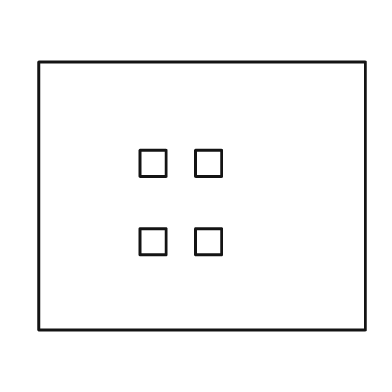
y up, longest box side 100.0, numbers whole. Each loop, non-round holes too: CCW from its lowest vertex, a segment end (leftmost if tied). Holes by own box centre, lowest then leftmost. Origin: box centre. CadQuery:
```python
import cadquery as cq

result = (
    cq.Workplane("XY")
    .moveTo(-50.0, -41.0)
    .lineTo(50.0, -41.0)
    .lineTo(50.0, 41.0)
    .lineTo(-50.0, 41.0)
    .close()
    .moveTo(-19.0, -18.0)
    .lineTo(-11.0, -18.0)
    .lineTo(-11.0, -10.0)
    .lineTo(-19.0, -10.0)
    .close()
    .moveTo(-2.0, -18.0)
    .lineTo(6.0, -18.0)
    .lineTo(6.0, -10.0)
    .lineTo(-2.0, -10.0)
    .close()
    .moveTo(-19.0, 6.0)
    .lineTo(-11.0, 6.0)
    .lineTo(-11.0, 14.0)
    .lineTo(-19.0, 14.0)
    .close()
    .moveTo(-2.0, 6.0)
    .lineTo(6.0, 6.0)
    .lineTo(6.0, 14.0)
    .lineTo(-2.0, 14.0)
    .close()
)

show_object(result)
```